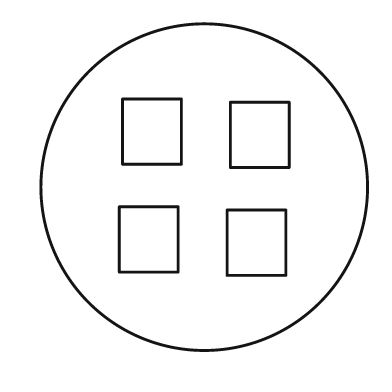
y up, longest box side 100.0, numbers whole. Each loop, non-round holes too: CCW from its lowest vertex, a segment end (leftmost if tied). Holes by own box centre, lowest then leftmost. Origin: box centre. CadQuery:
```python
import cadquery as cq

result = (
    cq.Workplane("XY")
    .moveTo(0.0, 0.0)
    .circle(50.0)
    .moveTo(7.0, -27.0)
    .lineTo(25.0, -27.0)
    .lineTo(25.0, -7.0)
    .lineTo(7.0, -7.0)
    .close()
    .moveTo(-26.0, -26.0)
    .lineTo(-8.0, -26.0)
    .lineTo(-8.0, -6.0)
    .lineTo(-26.0, -6.0)
    .close()
    .moveTo(8.0, 6.0)
    .lineTo(26.0, 6.0)
    .lineTo(26.0, 26.0)
    .lineTo(8.0, 26.0)
    .close()
    .moveTo(-25.0, 7.0)
    .lineTo(-7.0, 7.0)
    .lineTo(-7.0, 27.0)
    .lineTo(-25.0, 27.0)
    .close()
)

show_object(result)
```